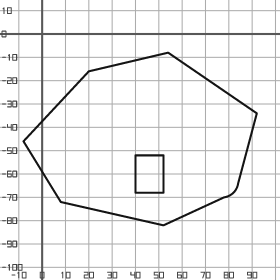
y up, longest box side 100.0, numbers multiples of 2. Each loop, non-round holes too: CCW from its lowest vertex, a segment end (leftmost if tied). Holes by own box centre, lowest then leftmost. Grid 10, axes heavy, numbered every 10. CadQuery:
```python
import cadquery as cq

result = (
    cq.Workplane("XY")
    .moveTo(52.0, -82.0)
    .lineTo(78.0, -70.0)
    .threePointArc((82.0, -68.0), (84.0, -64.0))
    .lineTo(92.0, -34.0)
    .lineTo(54.0, -8.0)
    .lineTo(20.0, -16.0)
    .lineTo(-8.0, -46.0)
    .lineTo(8.0, -72.0)
    .close()
    .moveTo(40.0, -68.0)
    .lineTo(52.0, -68.0)
    .lineTo(52.0, -52.0)
    .lineTo(40.0, -52.0)
    .close()
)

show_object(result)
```